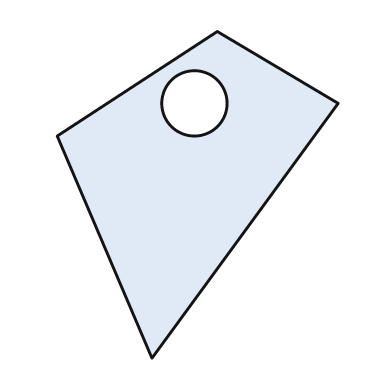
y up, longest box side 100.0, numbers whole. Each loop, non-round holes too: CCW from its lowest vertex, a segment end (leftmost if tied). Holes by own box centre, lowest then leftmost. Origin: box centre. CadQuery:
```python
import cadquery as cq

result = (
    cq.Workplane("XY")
    .moveTo(-14.0, -50.0)
    .lineTo(43.0, 28.0)
    .lineTo(6.0, 50.0)
    .lineTo(-43.0, 18.0)
    .close()
    .moveTo(-1.0, 28.0)
    .circle(10.0)
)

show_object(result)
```